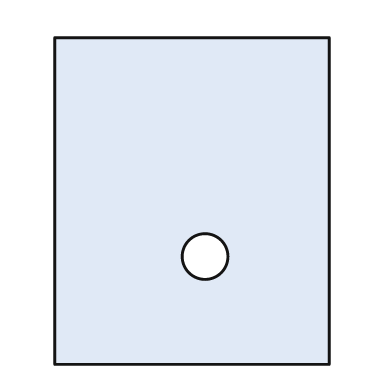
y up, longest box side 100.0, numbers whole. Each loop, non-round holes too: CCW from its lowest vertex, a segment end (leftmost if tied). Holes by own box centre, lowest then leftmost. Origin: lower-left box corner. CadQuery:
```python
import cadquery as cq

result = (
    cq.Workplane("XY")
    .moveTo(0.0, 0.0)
    .lineTo(84.0, 0.0)
    .lineTo(84.0, 100.0)
    .lineTo(0.0, 100.0)
    .close()
    .moveTo(46.0, 33.0)
    .circle(7.0)
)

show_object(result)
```